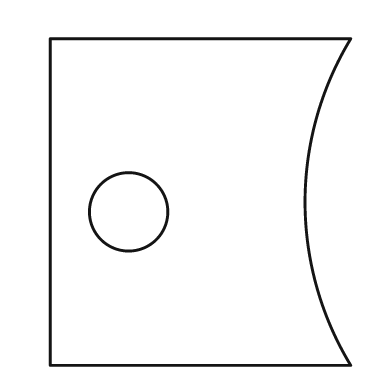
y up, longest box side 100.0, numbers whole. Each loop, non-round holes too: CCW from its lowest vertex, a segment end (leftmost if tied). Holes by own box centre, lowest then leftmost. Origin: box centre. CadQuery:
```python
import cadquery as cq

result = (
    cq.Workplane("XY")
    .moveTo(-46.0, -50.0)
    .lineTo(46.0, -50.0)
    .threePointArc((32.0, 0.0), (46.0, 50.0))
    .lineTo(-46.0, 50.0)
    .close()
    .moveTo(-22.0, -3.0)
    .circle(12.0)
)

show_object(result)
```